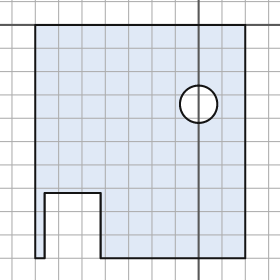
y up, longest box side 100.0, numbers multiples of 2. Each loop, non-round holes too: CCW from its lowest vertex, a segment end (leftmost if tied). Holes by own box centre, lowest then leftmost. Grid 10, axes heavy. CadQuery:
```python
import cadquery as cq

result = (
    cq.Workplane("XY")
    .moveTo(-70.0, -100.0)
    .lineTo(-66.0, -100.0)
    .lineTo(-66.0, -72.0)
    .lineTo(-42.0, -72.0)
    .lineTo(-42.0, -100.0)
    .lineTo(20.0, -100.0)
    .lineTo(20.0, 0.0)
    .lineTo(-70.0, 0.0)
    .close()
    .moveTo(0.0, -34.0)
    .circle(8.0)
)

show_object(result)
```